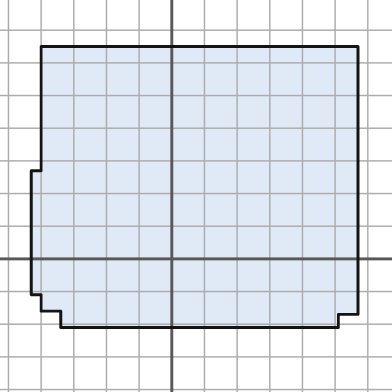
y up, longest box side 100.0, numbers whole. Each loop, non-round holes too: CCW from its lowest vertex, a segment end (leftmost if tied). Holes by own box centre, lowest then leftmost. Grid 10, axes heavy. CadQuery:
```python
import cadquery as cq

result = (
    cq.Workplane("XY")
    .moveTo(-34.0, -21.0)
    .lineTo(51.0, -21.0)
    .lineTo(51.0, -17.0)
    .lineTo(57.0, -17.0)
    .lineTo(57.0, 65.0)
    .lineTo(-40.0, 65.0)
    .lineTo(-40.0, 27.0)
    .lineTo(-43.0, 27.0)
    .lineTo(-43.0, -11.0)
    .lineTo(-40.0, -11.0)
    .lineTo(-40.0, -16.0)
    .lineTo(-34.0, -16.0)
    .close()
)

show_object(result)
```